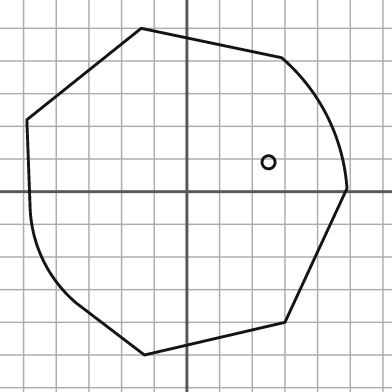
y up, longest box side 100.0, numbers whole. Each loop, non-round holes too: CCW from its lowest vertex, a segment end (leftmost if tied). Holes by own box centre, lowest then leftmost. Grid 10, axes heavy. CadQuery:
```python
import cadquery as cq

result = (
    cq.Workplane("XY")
    .moveTo(-13.0, -50.0)
    .lineTo(30.0, -40.0)
    .lineTo(49.0, 1.0)
    .threePointArc((43.0, 23.0), (29.0, 41.0))
    .lineTo(-14.0, 50.0)
    .lineTo(-49.0, 22.0)
    .lineTo(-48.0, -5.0)
    .threePointArc((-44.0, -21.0), (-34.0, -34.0))
    .close()
    .moveTo(25.0, 9.0)
    .circle(2.0)
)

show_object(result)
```